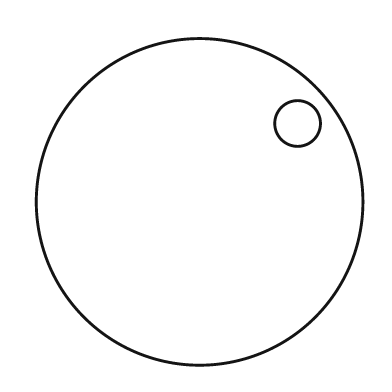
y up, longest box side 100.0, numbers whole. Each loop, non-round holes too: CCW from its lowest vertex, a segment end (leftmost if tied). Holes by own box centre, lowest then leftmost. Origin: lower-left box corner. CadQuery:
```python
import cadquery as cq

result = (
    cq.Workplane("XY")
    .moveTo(50.0, 50.0)
    .circle(50.0)
    .moveTo(80.0, 74.0)
    .circle(7.0)
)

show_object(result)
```